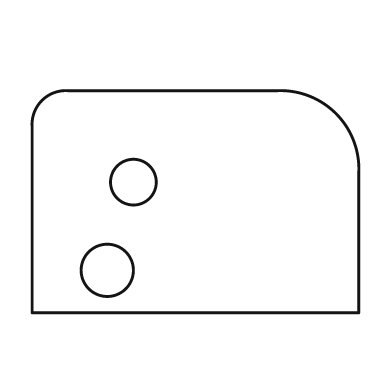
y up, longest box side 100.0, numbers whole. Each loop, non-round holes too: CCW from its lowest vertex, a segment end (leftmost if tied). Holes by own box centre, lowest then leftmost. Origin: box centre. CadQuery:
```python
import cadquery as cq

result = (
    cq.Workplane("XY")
    .moveTo(-50.0, -34.0)
    .lineTo(50.0, -34.0)
    .lineTo(50.0, 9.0)
    .threePointArc((43.0, 27.0), (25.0, 34.0))
    .lineTo(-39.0, 34.0)
    .threePointArc((-47.0, 31.0), (-50.0, 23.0))
    .close()
    .moveTo(-27.0, -21.0)
    .circle(8.0)
    .moveTo(-19.0, 6.0)
    .circle(7.0)
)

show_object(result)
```